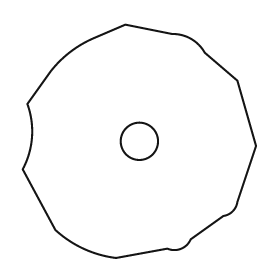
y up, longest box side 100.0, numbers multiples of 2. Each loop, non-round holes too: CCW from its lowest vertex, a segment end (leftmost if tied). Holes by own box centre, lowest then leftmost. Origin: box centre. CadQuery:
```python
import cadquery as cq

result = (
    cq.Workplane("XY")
    .moveTo(-10.0, -50.0)
    .lineTo(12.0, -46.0)
    .threePointArc((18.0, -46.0), (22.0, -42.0))
    .lineTo(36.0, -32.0)
    .threePointArc((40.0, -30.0), (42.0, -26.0))
    .lineTo(50.0, -2.0)
    .lineTo(42.0, 26.0)
    .lineTo(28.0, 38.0)
    .threePointArc((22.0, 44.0), (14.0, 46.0))
    .lineTo(-6.0, 50.0)
    .lineTo(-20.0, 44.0)
    .threePointArc((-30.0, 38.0), (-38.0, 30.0))
    .lineTo(-48.0, 16.0)
    .threePointArc((-46.0, 2.0), (-50.0, -12.0))
    .lineTo(-36.0, -38.0)
    .threePointArc((-24.0, -46.0), (-10.0, -50.0))
    .close()
    .moveTo(0.0, 0.0)
    .circle(8.0)
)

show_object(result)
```